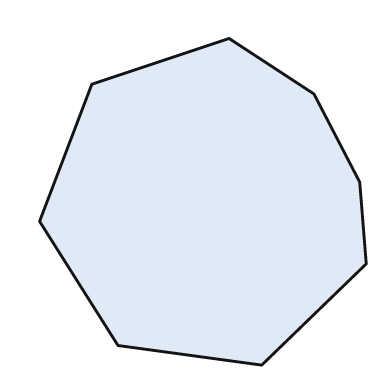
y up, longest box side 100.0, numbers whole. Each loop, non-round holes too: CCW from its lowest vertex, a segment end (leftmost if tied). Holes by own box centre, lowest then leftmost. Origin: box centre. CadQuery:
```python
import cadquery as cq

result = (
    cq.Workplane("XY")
    .moveTo(18.0, -50.0)
    .lineTo(50.0, -19.0)
    .lineTo(48.0, 6.0)
    .lineTo(34.0, 33.0)
    .lineTo(8.0, 50.0)
    .lineTo(-34.0, 36.0)
    .lineTo(-50.0, -6.0)
    .lineTo(-26.0, -44.0)
    .close()
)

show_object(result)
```